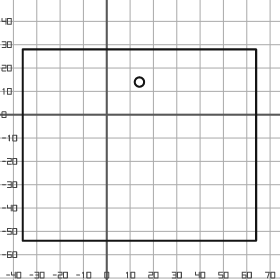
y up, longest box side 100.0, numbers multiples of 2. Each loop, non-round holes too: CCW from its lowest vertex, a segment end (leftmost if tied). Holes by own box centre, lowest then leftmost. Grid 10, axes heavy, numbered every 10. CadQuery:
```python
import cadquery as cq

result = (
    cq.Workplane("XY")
    .moveTo(-36.0, -54.0)
    .lineTo(64.0, -54.0)
    .lineTo(64.0, 28.0)
    .lineTo(-36.0, 28.0)
    .close()
    .moveTo(14.0, 14.0)
    .circle(2.0)
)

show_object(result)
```